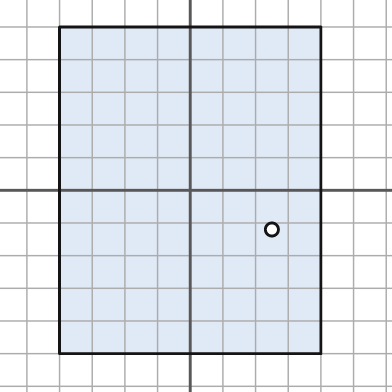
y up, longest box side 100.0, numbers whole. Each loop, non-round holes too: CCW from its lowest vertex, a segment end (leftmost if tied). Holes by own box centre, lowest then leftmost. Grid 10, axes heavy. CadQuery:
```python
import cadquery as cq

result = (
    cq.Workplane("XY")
    .moveTo(-40.0, -50.0)
    .lineTo(40.0, -50.0)
    .lineTo(40.0, 50.0)
    .lineTo(-40.0, 50.0)
    .close()
    .moveTo(25.0, -12.0)
    .circle(2.0)
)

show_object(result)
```